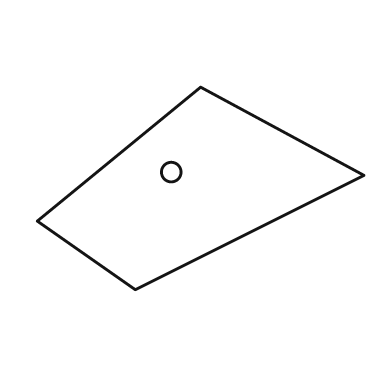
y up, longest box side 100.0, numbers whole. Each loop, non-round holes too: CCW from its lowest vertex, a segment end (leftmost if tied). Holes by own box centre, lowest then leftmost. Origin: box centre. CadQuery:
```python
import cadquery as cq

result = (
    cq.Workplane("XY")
    .moveTo(-20.0, -31.0)
    .lineTo(50.0, 4.0)
    .lineTo(0.0, 31.0)
    .lineTo(-50.0, -10.0)
    .close()
    .moveTo(-9.0, 5.0)
    .circle(3.0)
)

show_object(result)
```